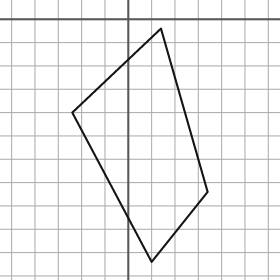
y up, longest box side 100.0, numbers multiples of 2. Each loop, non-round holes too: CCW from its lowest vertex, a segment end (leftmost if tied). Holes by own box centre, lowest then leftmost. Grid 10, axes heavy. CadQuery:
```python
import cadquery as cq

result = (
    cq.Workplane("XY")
    .moveTo(10.0, -104.0)
    .lineTo(34.0, -74.0)
    .lineTo(14.0, -4.0)
    .lineTo(-24.0, -40.0)
    .close()
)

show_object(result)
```